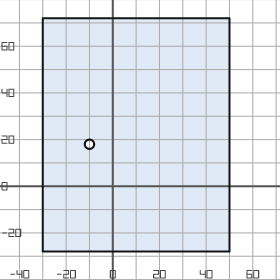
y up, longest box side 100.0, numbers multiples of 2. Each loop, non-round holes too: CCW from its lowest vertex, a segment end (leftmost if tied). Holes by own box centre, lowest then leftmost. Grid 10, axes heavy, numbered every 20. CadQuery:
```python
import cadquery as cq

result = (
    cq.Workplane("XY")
    .moveTo(-30.0, -28.0)
    .lineTo(50.0, -28.0)
    .lineTo(50.0, 72.0)
    .lineTo(-30.0, 72.0)
    .close()
    .moveTo(-10.0, 18.0)
    .circle(2.0)
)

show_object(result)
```